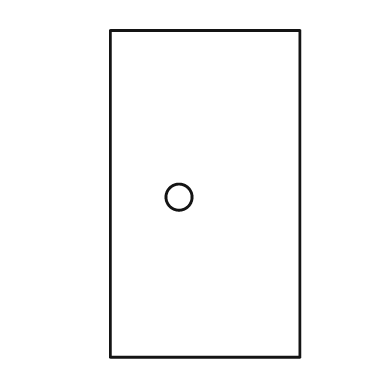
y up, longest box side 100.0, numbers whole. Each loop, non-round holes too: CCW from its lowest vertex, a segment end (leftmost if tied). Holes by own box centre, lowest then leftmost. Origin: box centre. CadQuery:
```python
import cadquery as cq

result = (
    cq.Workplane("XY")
    .moveTo(-29.0, -50.0)
    .lineTo(29.0, -50.0)
    .lineTo(29.0, 50.0)
    .lineTo(-29.0, 50.0)
    .close()
    .moveTo(-8.0, -1.0)
    .circle(4.0)
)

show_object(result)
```